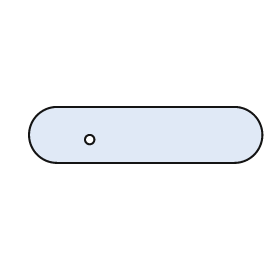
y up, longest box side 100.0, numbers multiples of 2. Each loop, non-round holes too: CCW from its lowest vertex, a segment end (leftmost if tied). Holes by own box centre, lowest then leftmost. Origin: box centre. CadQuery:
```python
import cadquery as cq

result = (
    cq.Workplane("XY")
    .moveTo(-38.0, -12.0)
    .lineTo(38.0, -12.0)
    .threePointArc((50.0, 0.0), (38.0, 12.0))
    .lineTo(-38.0, 12.0)
    .threePointArc((-50.0, 0.0), (-38.0, -12.0))
    .close()
    .moveTo(-24.0, -2.0)
    .circle(2.0)
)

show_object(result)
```